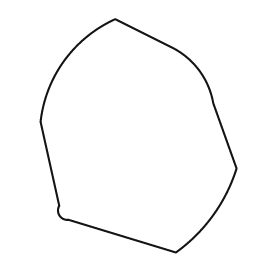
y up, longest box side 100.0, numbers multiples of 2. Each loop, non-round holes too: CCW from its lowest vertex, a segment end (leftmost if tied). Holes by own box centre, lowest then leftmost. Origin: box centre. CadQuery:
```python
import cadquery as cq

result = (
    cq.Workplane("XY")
    .moveTo(16.0, -50.0)
    .threePointArc((32.0, -34.0), (42.0, -14.0))
    .lineTo(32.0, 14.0)
    .threePointArc((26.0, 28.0), (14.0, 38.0))
    .lineTo(-10.0, 50.0)
    .threePointArc((-32.0, 32.0), (-42.0, 6.0))
    .lineTo(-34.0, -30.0)
    .threePointArc((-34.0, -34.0), (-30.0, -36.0))
    .close()
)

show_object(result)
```